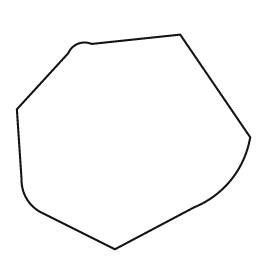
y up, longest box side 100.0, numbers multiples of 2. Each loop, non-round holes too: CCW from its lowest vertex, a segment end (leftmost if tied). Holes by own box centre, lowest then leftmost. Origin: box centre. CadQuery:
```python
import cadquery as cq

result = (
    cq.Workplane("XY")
    .moveTo(-8.0, -46.0)
    .lineTo(26.0, -28.0)
    .threePointArc((42.0, -16.0), (50.0, 2.0))
    .lineTo(20.0, 46.0)
    .lineTo(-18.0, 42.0)
    .threePointArc((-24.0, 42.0), (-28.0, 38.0))
    .lineTo(-50.0, 14.0)
    .lineTo(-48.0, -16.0)
    .threePointArc((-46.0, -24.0), (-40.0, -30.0))
    .close()
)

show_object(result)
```